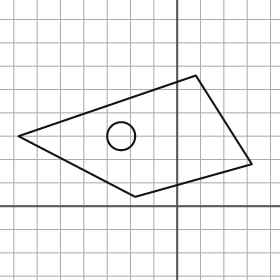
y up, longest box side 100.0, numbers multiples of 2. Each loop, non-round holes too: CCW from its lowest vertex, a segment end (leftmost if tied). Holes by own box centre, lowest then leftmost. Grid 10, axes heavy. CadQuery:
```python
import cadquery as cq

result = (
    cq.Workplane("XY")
    .moveTo(-18.0, 4.0)
    .lineTo(32.0, 18.0)
    .lineTo(8.0, 56.0)
    .lineTo(-68.0, 30.0)
    .close()
    .moveTo(-24.0, 30.0)
    .circle(6.0)
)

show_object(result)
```